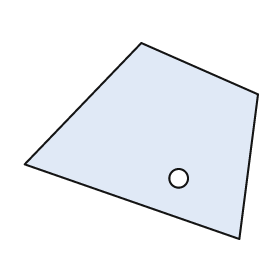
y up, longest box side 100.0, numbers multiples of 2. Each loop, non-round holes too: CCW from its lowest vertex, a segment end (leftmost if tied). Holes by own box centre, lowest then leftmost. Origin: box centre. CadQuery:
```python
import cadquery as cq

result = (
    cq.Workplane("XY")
    .moveTo(42.0, -42.0)
    .lineTo(50.0, 20.0)
    .lineTo(0.0, 42.0)
    .lineTo(-50.0, -10.0)
    .close()
    .moveTo(16.0, -16.0)
    .circle(4.0)
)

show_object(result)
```